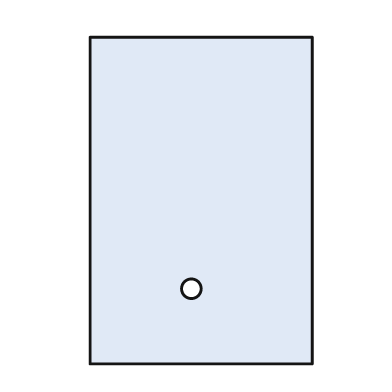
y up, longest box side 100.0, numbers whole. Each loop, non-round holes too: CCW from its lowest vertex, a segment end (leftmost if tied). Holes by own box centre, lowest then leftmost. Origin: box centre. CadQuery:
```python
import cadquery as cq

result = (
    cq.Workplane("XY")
    .moveTo(-34.0, -50.0)
    .lineTo(34.0, -50.0)
    .lineTo(34.0, 50.0)
    .lineTo(-34.0, 50.0)
    .close()
    .moveTo(-3.0, -27.0)
    .circle(3.0)
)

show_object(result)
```